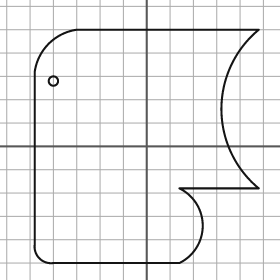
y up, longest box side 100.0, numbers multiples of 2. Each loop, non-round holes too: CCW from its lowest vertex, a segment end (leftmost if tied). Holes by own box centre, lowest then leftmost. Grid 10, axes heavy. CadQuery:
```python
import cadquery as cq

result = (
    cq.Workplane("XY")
    .moveTo(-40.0, -50.0)
    .lineTo(14.0, -50.0)
    .threePointArc((24.0, -34.0), (14.0, -18.0))
    .lineTo(48.0, -18.0)
    .threePointArc((32.0, 16.0), (48.0, 50.0))
    .lineTo(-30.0, 50.0)
    .threePointArc((-42.0, 44.0), (-48.0, 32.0))
    .lineTo(-48.0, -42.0)
    .threePointArc((-46.0, -48.0), (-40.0, -50.0))
    .close()
    .moveTo(-40.0, 28.0)
    .circle(2.0)
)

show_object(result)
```